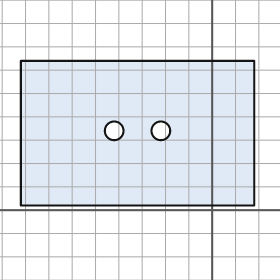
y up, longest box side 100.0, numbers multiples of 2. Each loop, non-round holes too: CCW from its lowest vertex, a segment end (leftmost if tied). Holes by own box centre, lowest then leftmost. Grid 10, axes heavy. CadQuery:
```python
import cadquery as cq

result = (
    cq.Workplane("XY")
    .moveTo(-82.0, 2.0)
    .lineTo(18.0, 2.0)
    .lineTo(18.0, 64.0)
    .lineTo(-82.0, 64.0)
    .close()
    .moveTo(-42.0, 34.0)
    .circle(4.0)
    .moveTo(-22.0, 34.0)
    .circle(4.0)
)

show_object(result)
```